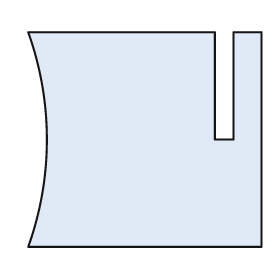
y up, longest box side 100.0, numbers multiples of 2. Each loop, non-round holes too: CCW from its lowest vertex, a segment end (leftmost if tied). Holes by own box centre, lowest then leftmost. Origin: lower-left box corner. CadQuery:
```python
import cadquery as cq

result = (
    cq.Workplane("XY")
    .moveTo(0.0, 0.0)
    .lineTo(100.0, 0.0)
    .lineTo(100.0, 92.0)
    .lineTo(88.0, 92.0)
    .lineTo(88.0, 46.0)
    .lineTo(80.0, 46.0)
    .lineTo(80.0, 92.0)
    .lineTo(0.0, 92.0)
    .threePointArc((8.0, 46.0), (0.0, 0.0))
    .close()
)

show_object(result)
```